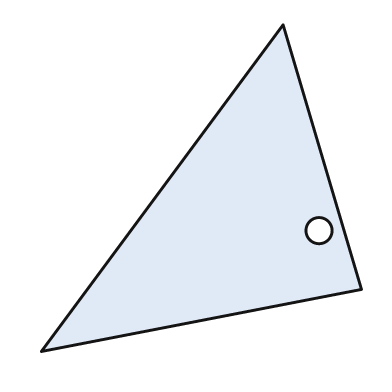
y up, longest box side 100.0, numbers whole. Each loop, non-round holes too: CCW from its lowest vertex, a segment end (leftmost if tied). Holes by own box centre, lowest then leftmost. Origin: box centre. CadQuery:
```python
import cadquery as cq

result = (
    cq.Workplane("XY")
    .moveTo(-49.0, -50.0)
    .lineTo(49.0, -31.0)
    .lineTo(25.0, 50.0)
    .close()
    .moveTo(36.0, -13.0)
    .circle(4.0)
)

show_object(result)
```